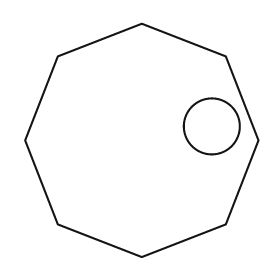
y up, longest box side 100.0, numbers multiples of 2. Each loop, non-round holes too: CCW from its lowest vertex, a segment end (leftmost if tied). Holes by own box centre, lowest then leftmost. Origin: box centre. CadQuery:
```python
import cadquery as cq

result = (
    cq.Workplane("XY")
    .moveTo(0.0, -50.0)
    .lineTo(36.0, -36.0)
    .lineTo(50.0, 0.0)
    .lineTo(36.0, 36.0)
    .lineTo(0.0, 50.0)
    .lineTo(-36.0, 36.0)
    .lineTo(-50.0, 0.0)
    .lineTo(-36.0, -36.0)
    .close()
    .moveTo(30.0, 6.0)
    .circle(12.0)
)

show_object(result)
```